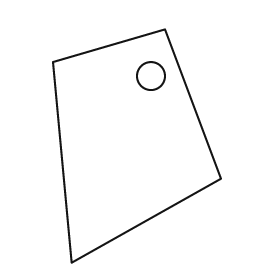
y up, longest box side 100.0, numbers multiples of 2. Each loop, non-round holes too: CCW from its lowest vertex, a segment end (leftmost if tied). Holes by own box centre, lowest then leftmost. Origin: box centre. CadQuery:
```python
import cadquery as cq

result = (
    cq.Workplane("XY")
    .moveTo(-28.0, -50.0)
    .lineTo(36.0, -14.0)
    .lineTo(12.0, 50.0)
    .lineTo(-36.0, 36.0)
    .close()
    .moveTo(6.0, 30.0)
    .circle(6.0)
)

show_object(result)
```